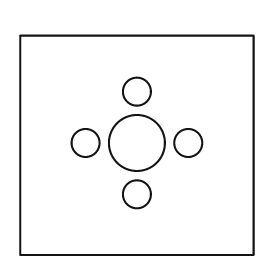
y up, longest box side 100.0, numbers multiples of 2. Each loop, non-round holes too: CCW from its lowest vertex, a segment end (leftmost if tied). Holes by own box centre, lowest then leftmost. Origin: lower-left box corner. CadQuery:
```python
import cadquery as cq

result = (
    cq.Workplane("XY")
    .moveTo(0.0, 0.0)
    .lineTo(100.0, 0.0)
    .lineTo(100.0, 94.0)
    .lineTo(0.0, 94.0)
    .close()
    .moveTo(50.0, 26.0)
    .circle(6.0)
    .moveTo(28.0, 48.0)
    .circle(6.0)
    .moveTo(50.0, 48.0)
    .circle(12.0)
    .moveTo(72.0, 48.0)
    .circle(6.0)
    .moveTo(50.0, 70.0)
    .circle(6.0)
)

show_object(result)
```